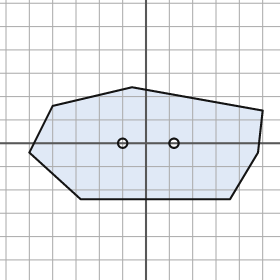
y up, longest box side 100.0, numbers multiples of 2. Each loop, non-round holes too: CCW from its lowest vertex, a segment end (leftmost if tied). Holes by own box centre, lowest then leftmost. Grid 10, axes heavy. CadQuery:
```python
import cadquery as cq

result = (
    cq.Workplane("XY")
    .moveTo(-28.0, -24.0)
    .lineTo(36.0, -24.0)
    .lineTo(48.0, -4.0)
    .lineTo(50.0, 14.0)
    .lineTo(-6.0, 24.0)
    .lineTo(-40.0, 16.0)
    .lineTo(-50.0, -4.0)
    .close()
    .moveTo(-10.0, 0.0)
    .circle(2.0)
    .moveTo(12.0, 0.0)
    .circle(2.0)
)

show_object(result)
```